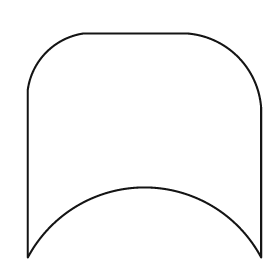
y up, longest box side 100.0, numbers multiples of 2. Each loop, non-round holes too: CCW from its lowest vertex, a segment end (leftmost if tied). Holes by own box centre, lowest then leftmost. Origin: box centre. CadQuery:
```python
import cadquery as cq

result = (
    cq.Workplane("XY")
    .moveTo(-50.0, -48.0)
    .threePointArc((0.0, -18.0), (50.0, -48.0))
    .lineTo(50.0, 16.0)
    .threePointArc((40.0, 38.0), (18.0, 48.0))
    .lineTo(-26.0, 48.0)
    .threePointArc((-42.0, 40.0), (-50.0, 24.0))
    .close()
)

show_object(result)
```